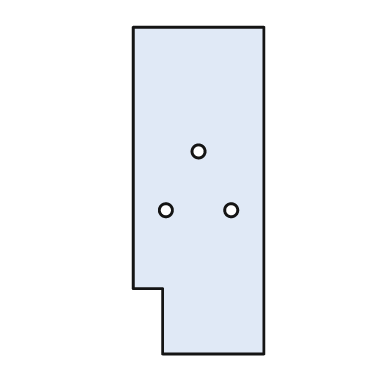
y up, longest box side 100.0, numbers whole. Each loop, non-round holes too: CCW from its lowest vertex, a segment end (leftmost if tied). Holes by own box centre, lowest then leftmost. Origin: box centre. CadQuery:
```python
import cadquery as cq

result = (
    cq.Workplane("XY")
    .moveTo(-11.0, -50.0)
    .lineTo(20.0, -50.0)
    .lineTo(20.0, 50.0)
    .lineTo(-20.0, 50.0)
    .lineTo(-20.0, -30.0)
    .lineTo(-11.0, -30.0)
    .close()
    .moveTo(-10.0, -6.0)
    .circle(2.0)
    .moveTo(10.0, -6.0)
    .circle(2.0)
    .moveTo(0.0, 12.0)
    .circle(2.0)
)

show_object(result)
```